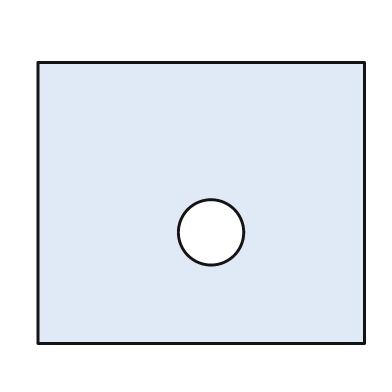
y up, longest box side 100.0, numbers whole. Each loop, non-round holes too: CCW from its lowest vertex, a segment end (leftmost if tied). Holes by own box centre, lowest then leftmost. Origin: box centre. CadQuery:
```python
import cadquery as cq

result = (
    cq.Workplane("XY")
    .moveTo(-50.0, -43.0)
    .lineTo(50.0, -43.0)
    .lineTo(50.0, 43.0)
    .lineTo(-50.0, 43.0)
    .close()
    .moveTo(3.0, -9.0)
    .circle(10.0)
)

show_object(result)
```